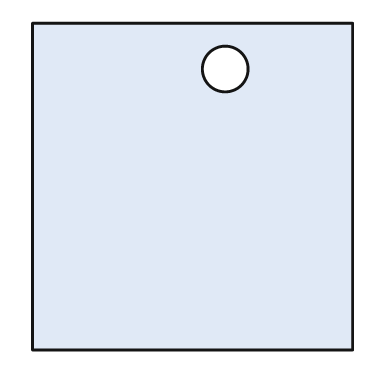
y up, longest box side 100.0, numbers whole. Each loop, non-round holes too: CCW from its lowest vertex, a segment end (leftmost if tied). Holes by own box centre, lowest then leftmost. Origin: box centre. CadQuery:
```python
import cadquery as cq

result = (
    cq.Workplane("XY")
    .moveTo(-49.0, -50.0)
    .lineTo(49.0, -50.0)
    .lineTo(49.0, 50.0)
    .lineTo(-49.0, 50.0)
    .close()
    .moveTo(10.0, 36.0)
    .circle(7.0)
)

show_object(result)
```